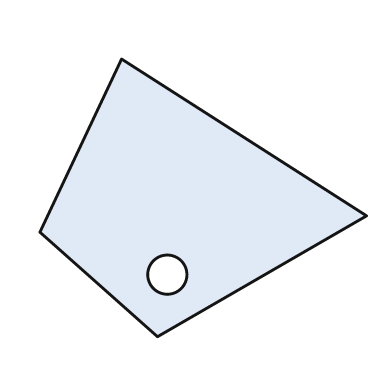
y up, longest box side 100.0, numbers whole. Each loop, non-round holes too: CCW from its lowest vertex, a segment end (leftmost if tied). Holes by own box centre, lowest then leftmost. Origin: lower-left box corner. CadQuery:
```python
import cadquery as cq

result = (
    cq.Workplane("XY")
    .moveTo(36.0, 0.0)
    .lineTo(100.0, 37.0)
    .lineTo(25.0, 85.0)
    .lineTo(0.0, 32.0)
    .close()
    .moveTo(39.0, 19.0)
    .circle(6.0)
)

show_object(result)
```